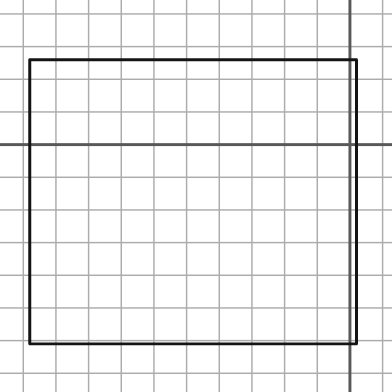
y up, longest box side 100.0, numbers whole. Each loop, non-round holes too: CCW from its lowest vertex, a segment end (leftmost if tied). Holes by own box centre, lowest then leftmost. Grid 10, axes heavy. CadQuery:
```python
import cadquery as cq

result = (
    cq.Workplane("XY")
    .moveTo(-98.0, -61.0)
    .lineTo(2.0, -61.0)
    .lineTo(2.0, 26.0)
    .lineTo(-98.0, 26.0)
    .close()
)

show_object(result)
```